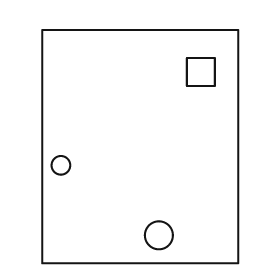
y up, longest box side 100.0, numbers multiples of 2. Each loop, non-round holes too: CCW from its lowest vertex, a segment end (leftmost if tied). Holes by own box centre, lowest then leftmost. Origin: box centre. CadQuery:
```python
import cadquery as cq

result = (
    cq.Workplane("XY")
    .moveTo(-42.0, -50.0)
    .lineTo(42.0, -50.0)
    .lineTo(42.0, 50.0)
    .lineTo(-42.0, 50.0)
    .close()
    .moveTo(8.0, -38.0)
    .circle(6.0)
    .moveTo(-34.0, -8.0)
    .circle(4.0)
    .moveTo(20.0, 26.0)
    .lineTo(32.0, 26.0)
    .lineTo(32.0, 38.0)
    .lineTo(20.0, 38.0)
    .close()
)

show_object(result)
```